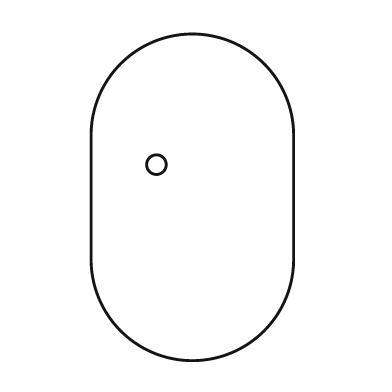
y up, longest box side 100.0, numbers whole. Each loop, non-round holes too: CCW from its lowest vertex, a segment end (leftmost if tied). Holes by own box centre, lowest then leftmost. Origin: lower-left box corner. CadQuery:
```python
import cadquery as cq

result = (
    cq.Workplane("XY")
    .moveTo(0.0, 31.0)
    .threePointArc((31.0, 0.0), (62.0, 31.0))
    .lineTo(62.0, 69.0)
    .threePointArc((31.0, 100.0), (0.0, 69.0))
    .close()
    .moveTo(20.0, 60.0)
    .circle(3.0)
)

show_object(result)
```